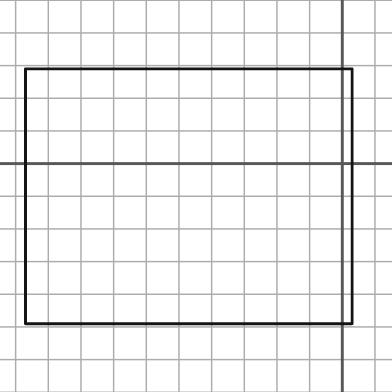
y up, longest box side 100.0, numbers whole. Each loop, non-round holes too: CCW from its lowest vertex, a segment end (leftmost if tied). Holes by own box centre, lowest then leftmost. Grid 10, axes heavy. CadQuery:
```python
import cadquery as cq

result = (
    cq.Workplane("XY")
    .moveTo(-97.0, -49.0)
    .lineTo(3.0, -49.0)
    .lineTo(3.0, 29.0)
    .lineTo(-97.0, 29.0)
    .close()
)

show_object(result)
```